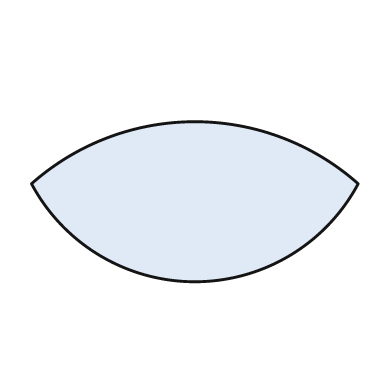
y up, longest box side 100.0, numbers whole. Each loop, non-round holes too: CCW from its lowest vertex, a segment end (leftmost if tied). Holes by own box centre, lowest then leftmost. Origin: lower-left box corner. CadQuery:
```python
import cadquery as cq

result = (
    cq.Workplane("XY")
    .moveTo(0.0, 30.0)
    .threePointArc((50.0, 0.0), (100.0, 30.0))
    .threePointArc((50.0, 49.0), (0.0, 30.0))
    .close()
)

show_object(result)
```